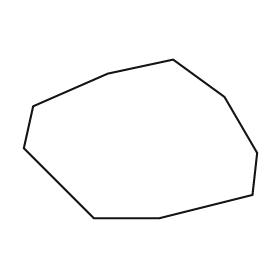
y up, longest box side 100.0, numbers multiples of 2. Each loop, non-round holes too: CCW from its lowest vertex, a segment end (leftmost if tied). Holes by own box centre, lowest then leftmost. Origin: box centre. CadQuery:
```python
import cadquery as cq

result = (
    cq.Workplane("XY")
    .moveTo(-20.0, -34.0)
    .lineTo(8.0, -34.0)
    .lineTo(48.0, -24.0)
    .lineTo(50.0, -6.0)
    .lineTo(36.0, 18.0)
    .lineTo(14.0, 34.0)
    .lineTo(-14.0, 28.0)
    .lineTo(-46.0, 14.0)
    .lineTo(-50.0, -4.0)
    .close()
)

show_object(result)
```